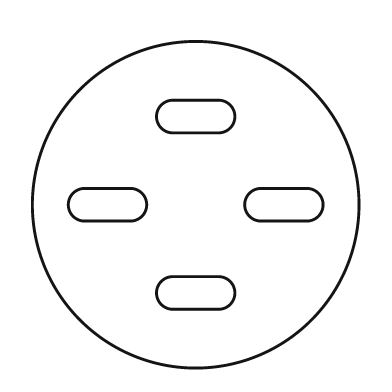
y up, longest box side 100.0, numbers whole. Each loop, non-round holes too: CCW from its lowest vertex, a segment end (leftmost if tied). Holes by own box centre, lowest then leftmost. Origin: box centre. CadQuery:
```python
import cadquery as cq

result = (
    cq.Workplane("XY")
    .moveTo(0.0, 0.0)
    .circle(50.0)
    .moveTo(-7.0, -32.0)
    .lineTo(7.0, -32.0)
    .threePointArc((12.0, -27.0), (7.0, -22.0))
    .lineTo(-7.0, -22.0)
    .threePointArc((-12.0, -27.0), (-7.0, -32.0))
    .close()
    .moveTo(-34.0, -5.0)
    .lineTo(-20.0, -5.0)
    .threePointArc((-15.0, 0.0), (-20.0, 5.0))
    .lineTo(-34.0, 5.0)
    .threePointArc((-39.0, 0.0), (-34.0, -5.0))
    .close()
    .moveTo(20.0, -5.0)
    .lineTo(34.0, -5.0)
    .threePointArc((39.0, 0.0), (34.0, 5.0))
    .lineTo(20.0, 5.0)
    .threePointArc((15.0, 0.0), (20.0, -5.0))
    .close()
    .moveTo(-7.0, 22.0)
    .lineTo(7.0, 22.0)
    .threePointArc((12.0, 27.0), (7.0, 32.0))
    .lineTo(-7.0, 32.0)
    .threePointArc((-12.0, 27.0), (-7.0, 22.0))
    .close()
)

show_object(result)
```